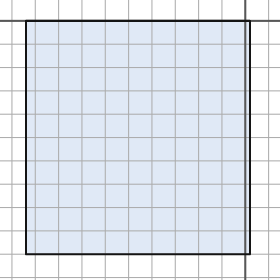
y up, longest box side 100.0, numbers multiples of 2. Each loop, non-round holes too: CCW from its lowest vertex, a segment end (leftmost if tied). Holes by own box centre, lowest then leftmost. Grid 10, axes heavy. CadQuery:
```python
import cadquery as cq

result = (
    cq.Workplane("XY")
    .moveTo(-94.0, -100.0)
    .lineTo(2.0, -100.0)
    .lineTo(2.0, 0.0)
    .lineTo(-94.0, 0.0)
    .close()
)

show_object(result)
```